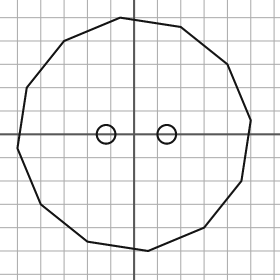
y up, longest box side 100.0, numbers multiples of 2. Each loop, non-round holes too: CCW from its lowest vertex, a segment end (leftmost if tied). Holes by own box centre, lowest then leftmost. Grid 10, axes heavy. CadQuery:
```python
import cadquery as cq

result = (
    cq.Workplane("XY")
    .moveTo(6.0, -50.0)
    .lineTo(30.0, -40.0)
    .lineTo(46.0, -20.0)
    .lineTo(50.0, 6.0)
    .lineTo(40.0, 30.0)
    .lineTo(20.0, 46.0)
    .lineTo(-6.0, 50.0)
    .lineTo(-30.0, 40.0)
    .lineTo(-46.0, 20.0)
    .lineTo(-50.0, -6.0)
    .lineTo(-40.0, -30.0)
    .lineTo(-20.0, -46.0)
    .close()
    .moveTo(-12.0, 0.0)
    .circle(4.0)
    .moveTo(14.0, 0.0)
    .circle(4.0)
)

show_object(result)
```